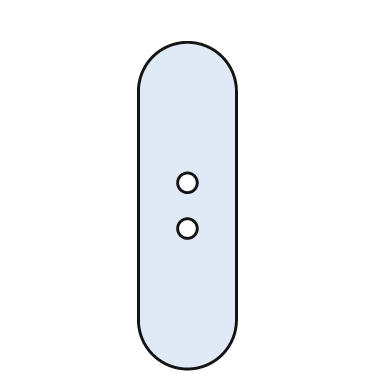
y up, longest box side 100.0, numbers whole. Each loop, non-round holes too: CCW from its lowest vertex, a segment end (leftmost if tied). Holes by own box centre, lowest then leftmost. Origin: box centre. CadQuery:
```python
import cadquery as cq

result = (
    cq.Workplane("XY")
    .moveTo(-15.0, -35.0)
    .threePointArc((0.0, -50.0), (15.0, -35.0))
    .lineTo(15.0, 35.0)
    .threePointArc((0.0, 50.0), (-15.0, 35.0))
    .close()
    .moveTo(0.0, -7.0)
    .circle(3.0)
    .moveTo(0.0, 7.0)
    .circle(3.0)
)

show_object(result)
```